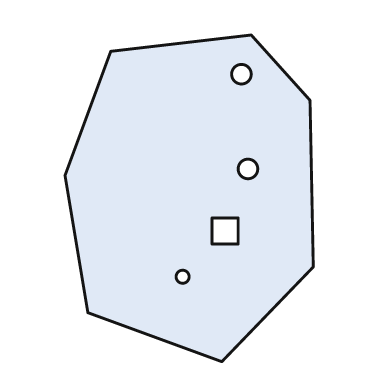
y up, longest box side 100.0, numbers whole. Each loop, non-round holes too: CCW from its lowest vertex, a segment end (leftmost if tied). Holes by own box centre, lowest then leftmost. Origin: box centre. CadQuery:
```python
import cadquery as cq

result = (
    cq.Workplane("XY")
    .moveTo(10.0, -50.0)
    .lineTo(38.0, -21.0)
    .lineTo(37.0, 30.0)
    .lineTo(19.0, 50.0)
    .lineTo(-24.0, 45.0)
    .lineTo(-38.0, 7.0)
    .lineTo(-31.0, -35.0)
    .close()
    .moveTo(-2.0, -24.0)
    .circle(2.0)
    .moveTo(7.0, -14.0)
    .lineTo(15.0, -14.0)
    .lineTo(15.0, -6.0)
    .lineTo(7.0, -6.0)
    .close()
    .moveTo(18.0, 9.0)
    .circle(3.0)
    .moveTo(16.0, 38.0)
    .circle(3.0)
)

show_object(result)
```